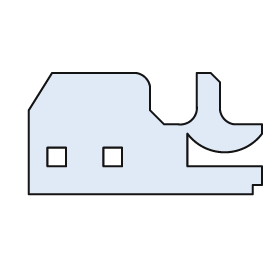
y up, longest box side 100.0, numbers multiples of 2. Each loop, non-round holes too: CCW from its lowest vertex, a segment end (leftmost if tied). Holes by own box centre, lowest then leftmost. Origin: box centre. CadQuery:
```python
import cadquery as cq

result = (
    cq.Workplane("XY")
    .moveTo(-50.0, -26.0)
    .lineTo(46.0, -26.0)
    .lineTo(46.0, -22.0)
    .lineTo(50.0, -22.0)
    .lineTo(50.0, -14.0)
    .lineTo(18.0, -14.0)
    .lineTo(18.0, 0.0)
    .threePointArc((34.0, -8.0), (50.0, 0.0))
    .lineTo(50.0, 4.0)
    .lineTo(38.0, 4.0)
    .threePointArc((34.0, 6.0), (32.0, 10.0))
    .lineTo(32.0, 22.0)
    .lineTo(28.0, 26.0)
    .lineTo(22.0, 26.0)
    .lineTo(22.0, 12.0)
    .threePointArc((20.0, 6.0), (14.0, 4.0))
    .lineTo(8.0, 4.0)
    .lineTo(2.0, 10.0)
    .lineTo(2.0, 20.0)
    .threePointArc((0.0, 24.0), (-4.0, 26.0))
    .lineTo(-40.0, 26.0)
    .lineTo(-50.0, 10.0)
    .close()
    .moveTo(-42.0, -14.0)
    .lineTo(-34.0, -14.0)
    .lineTo(-34.0, -6.0)
    .lineTo(-42.0, -6.0)
    .close()
    .moveTo(-18.0, -14.0)
    .lineTo(-10.0, -14.0)
    .lineTo(-10.0, -6.0)
    .lineTo(-18.0, -6.0)
    .close()
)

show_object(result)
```